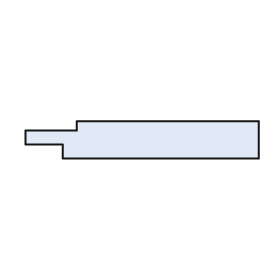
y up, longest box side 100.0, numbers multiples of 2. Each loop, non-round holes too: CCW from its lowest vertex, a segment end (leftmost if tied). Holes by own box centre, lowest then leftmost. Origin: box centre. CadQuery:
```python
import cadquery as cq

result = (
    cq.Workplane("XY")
    .moveTo(-34.0, -8.0)
    .lineTo(50.0, -8.0)
    .lineTo(50.0, 8.0)
    .lineTo(-28.0, 8.0)
    .lineTo(-28.0, 4.0)
    .lineTo(-50.0, 4.0)
    .lineTo(-50.0, -2.0)
    .lineTo(-34.0, -2.0)
    .close()
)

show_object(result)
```